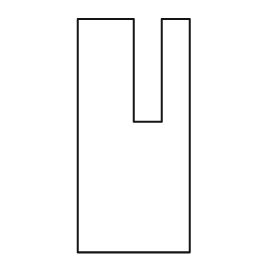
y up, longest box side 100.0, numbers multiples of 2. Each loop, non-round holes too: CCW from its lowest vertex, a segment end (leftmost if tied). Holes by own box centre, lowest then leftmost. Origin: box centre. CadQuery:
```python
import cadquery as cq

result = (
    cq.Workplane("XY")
    .moveTo(-24.0, -50.0)
    .lineTo(24.0, -50.0)
    .lineTo(24.0, 50.0)
    .lineTo(12.0, 50.0)
    .lineTo(12.0, 6.0)
    .lineTo(0.0, 6.0)
    .lineTo(0.0, 50.0)
    .lineTo(-24.0, 50.0)
    .close()
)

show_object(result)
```